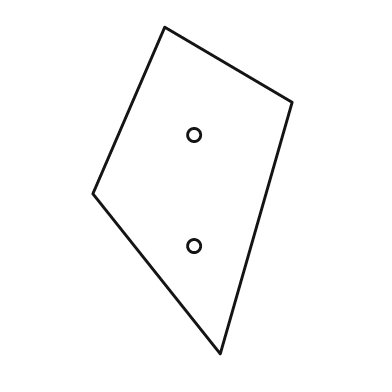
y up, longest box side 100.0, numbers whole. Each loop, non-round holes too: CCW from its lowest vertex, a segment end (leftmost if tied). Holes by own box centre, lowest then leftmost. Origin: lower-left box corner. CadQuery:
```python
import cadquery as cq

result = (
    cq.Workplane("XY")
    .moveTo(39.0, 0.0)
    .lineTo(61.0, 77.0)
    .lineTo(22.0, 100.0)
    .lineTo(0.0, 49.0)
    .close()
    .moveTo(31.0, 33.0)
    .circle(2.0)
    .moveTo(31.0, 67.0)
    .circle(2.0)
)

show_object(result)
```